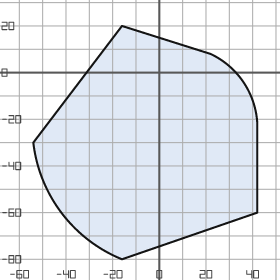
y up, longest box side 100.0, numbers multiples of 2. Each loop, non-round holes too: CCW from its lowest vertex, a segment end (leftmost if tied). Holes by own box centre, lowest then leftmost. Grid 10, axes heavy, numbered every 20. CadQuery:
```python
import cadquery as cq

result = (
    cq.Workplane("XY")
    .moveTo(-16.0, -80.0)
    .lineTo(42.0, -60.0)
    .lineTo(42.0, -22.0)
    .threePointArc((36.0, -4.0), (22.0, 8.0))
    .lineTo(-16.0, 20.0)
    .lineTo(-54.0, -30.0)
    .threePointArc((-42.0, -60.0), (-16.0, -80.0))
    .close()
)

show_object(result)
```